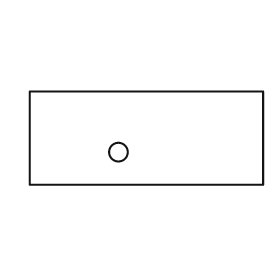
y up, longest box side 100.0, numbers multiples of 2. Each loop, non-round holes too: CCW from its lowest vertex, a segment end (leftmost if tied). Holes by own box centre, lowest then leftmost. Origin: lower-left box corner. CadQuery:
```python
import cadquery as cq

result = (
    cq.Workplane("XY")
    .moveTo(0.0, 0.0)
    .lineTo(100.0, 0.0)
    .lineTo(100.0, 40.0)
    .lineTo(0.0, 40.0)
    .close()
    .moveTo(38.0, 14.0)
    .circle(4.0)
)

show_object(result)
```